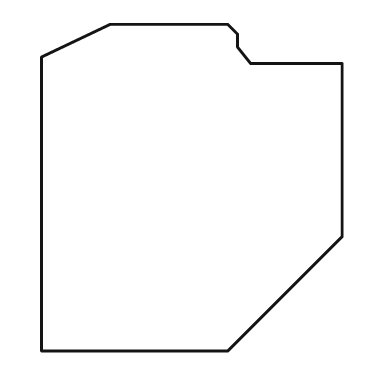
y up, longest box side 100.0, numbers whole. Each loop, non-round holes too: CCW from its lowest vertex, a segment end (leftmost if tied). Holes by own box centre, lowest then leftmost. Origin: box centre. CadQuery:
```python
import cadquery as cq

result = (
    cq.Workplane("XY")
    .moveTo(-46.0, -50.0)
    .lineTo(11.0, -50.0)
    .lineTo(46.0, -15.0)
    .lineTo(46.0, 38.0)
    .lineTo(18.0, 38.0)
    .lineTo(14.0, 43.0)
    .lineTo(14.0, 47.0)
    .lineTo(11.0, 50.0)
    .lineTo(-25.0, 50.0)
    .lineTo(-46.0, 40.0)
    .close()
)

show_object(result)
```